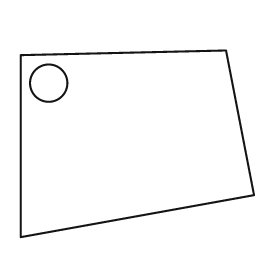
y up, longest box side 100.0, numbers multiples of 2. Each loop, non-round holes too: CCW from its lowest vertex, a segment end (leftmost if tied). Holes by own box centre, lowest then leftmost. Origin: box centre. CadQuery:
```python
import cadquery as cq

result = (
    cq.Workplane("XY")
    .moveTo(-50.0, -40.0)
    .lineTo(50.0, -22.0)
    .lineTo(38.0, 40.0)
    .lineTo(-50.0, 38.0)
    .close()
    .moveTo(-38.0, 26.0)
    .circle(8.0)
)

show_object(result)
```